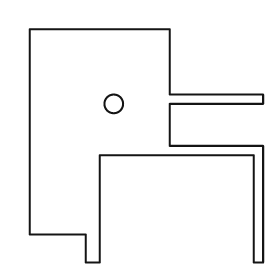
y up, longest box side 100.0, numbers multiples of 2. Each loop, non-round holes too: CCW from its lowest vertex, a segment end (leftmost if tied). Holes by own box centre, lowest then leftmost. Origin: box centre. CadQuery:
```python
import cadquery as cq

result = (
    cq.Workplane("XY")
    .moveTo(-26.0, -50.0)
    .lineTo(-20.0, -50.0)
    .lineTo(-20.0, -4.0)
    .lineTo(46.0, -4.0)
    .lineTo(46.0, -50.0)
    .lineTo(50.0, -50.0)
    .lineTo(50.0, 0.0)
    .lineTo(10.0, 0.0)
    .lineTo(10.0, 18.0)
    .lineTo(50.0, 18.0)
    .lineTo(50.0, 22.0)
    .lineTo(10.0, 22.0)
    .lineTo(10.0, 50.0)
    .lineTo(-50.0, 50.0)
    .lineTo(-50.0, -38.0)
    .lineTo(-26.0, -38.0)
    .close()
    .moveTo(-14.0, 18.0)
    .circle(4.0)
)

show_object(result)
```